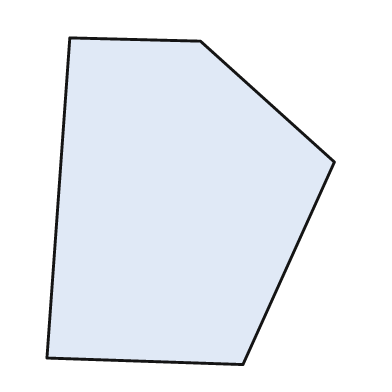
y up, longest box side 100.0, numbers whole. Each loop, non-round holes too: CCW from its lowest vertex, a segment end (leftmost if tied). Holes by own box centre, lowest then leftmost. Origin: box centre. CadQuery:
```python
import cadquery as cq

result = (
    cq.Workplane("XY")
    .moveTo(16.0, -50.0)
    .lineTo(44.0, 12.0)
    .lineTo(3.0, 49.0)
    .lineTo(-37.0, 50.0)
    .lineTo(-44.0, -48.0)
    .close()
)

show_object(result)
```